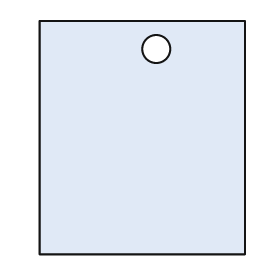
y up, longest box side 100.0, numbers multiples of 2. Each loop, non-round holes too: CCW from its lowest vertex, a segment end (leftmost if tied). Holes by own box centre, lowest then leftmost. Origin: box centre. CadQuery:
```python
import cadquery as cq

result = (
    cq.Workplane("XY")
    .moveTo(-44.0, -50.0)
    .lineTo(44.0, -50.0)
    .lineTo(44.0, 50.0)
    .lineTo(-44.0, 50.0)
    .close()
    .moveTo(6.0, 38.0)
    .circle(6.0)
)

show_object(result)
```